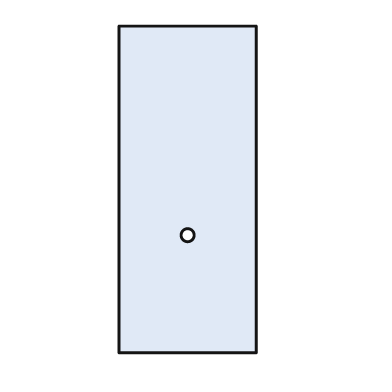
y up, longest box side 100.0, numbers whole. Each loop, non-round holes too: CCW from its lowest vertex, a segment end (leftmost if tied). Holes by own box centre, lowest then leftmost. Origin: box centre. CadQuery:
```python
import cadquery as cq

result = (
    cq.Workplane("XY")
    .moveTo(-21.0, -50.0)
    .lineTo(21.0, -50.0)
    .lineTo(21.0, 50.0)
    .lineTo(-21.0, 50.0)
    .close()
    .moveTo(0.0, -14.0)
    .circle(2.0)
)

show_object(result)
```